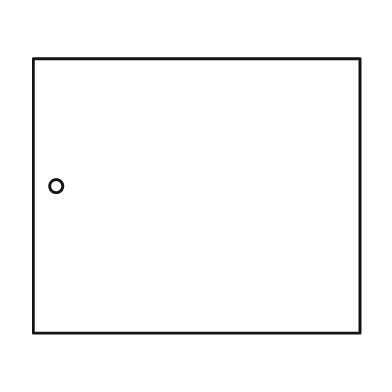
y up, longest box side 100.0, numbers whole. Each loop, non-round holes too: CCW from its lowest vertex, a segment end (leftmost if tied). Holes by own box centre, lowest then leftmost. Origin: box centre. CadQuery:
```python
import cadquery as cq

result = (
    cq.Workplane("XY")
    .moveTo(-50.0, -42.0)
    .lineTo(50.0, -42.0)
    .lineTo(50.0, 42.0)
    .lineTo(-50.0, 42.0)
    .close()
    .moveTo(-43.0, 3.0)
    .circle(2.0)
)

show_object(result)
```